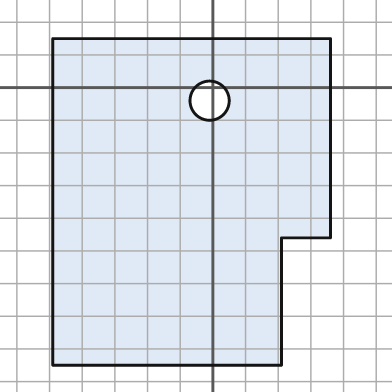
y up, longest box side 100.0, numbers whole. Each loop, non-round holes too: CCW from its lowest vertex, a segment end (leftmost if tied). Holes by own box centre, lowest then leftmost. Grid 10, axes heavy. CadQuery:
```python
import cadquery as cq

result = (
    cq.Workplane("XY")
    .moveTo(-49.0, -85.0)
    .lineTo(21.0, -85.0)
    .lineTo(21.0, -46.0)
    .lineTo(36.0, -46.0)
    .lineTo(36.0, 15.0)
    .lineTo(-49.0, 15.0)
    .close()
    .moveTo(-1.0, -4.0)
    .circle(6.0)
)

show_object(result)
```